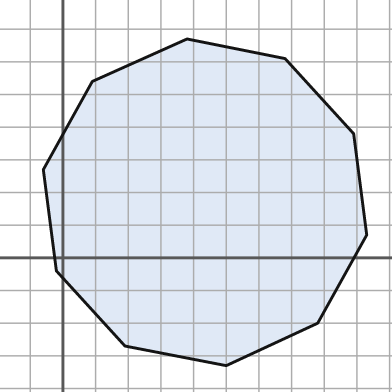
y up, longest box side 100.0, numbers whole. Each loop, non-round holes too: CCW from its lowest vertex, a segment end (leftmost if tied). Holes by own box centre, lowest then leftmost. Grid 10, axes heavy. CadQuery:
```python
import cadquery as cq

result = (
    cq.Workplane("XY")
    .moveTo(50.0, -33.0)
    .lineTo(78.0, -20.0)
    .lineTo(93.0, 7.0)
    .lineTo(89.0, 38.0)
    .lineTo(68.0, 61.0)
    .lineTo(38.0, 67.0)
    .lineTo(9.0, 54.0)
    .lineTo(-6.0, 27.0)
    .lineTo(-2.0, -4.0)
    .lineTo(19.0, -27.0)
    .close()
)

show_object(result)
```